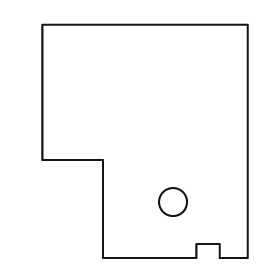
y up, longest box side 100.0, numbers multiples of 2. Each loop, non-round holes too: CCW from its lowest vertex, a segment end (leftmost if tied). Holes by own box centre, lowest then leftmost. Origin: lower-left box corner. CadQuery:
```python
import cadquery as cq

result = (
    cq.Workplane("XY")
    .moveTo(26.0, 0.0)
    .lineTo(66.0, 0.0)
    .lineTo(66.0, 6.0)
    .lineTo(76.0, 6.0)
    .lineTo(76.0, 0.0)
    .lineTo(88.0, 0.0)
    .lineTo(88.0, 100.0)
    .lineTo(0.0, 100.0)
    .lineTo(0.0, 42.0)
    .lineTo(26.0, 42.0)
    .close()
    .moveTo(56.0, 24.0)
    .circle(6.0)
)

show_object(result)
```